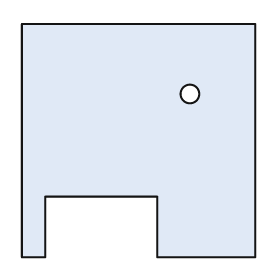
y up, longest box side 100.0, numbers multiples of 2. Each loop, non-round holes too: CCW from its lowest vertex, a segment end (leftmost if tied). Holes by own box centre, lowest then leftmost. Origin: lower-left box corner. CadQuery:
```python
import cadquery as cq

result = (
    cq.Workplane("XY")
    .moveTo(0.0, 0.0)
    .lineTo(10.0, 0.0)
    .lineTo(10.0, 26.0)
    .lineTo(58.0, 26.0)
    .lineTo(58.0, 0.0)
    .lineTo(100.0, 0.0)
    .lineTo(100.0, 100.0)
    .lineTo(0.0, 100.0)
    .close()
    .moveTo(72.0, 70.0)
    .circle(4.0)
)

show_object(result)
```